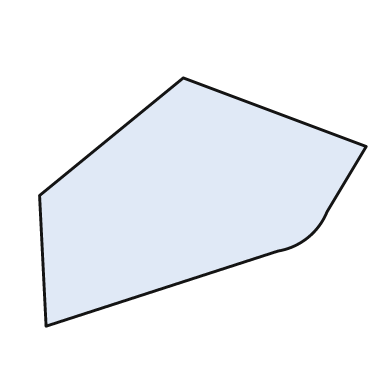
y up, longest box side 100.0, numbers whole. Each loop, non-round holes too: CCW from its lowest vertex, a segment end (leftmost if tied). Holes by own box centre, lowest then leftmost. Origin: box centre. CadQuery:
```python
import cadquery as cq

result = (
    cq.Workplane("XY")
    .moveTo(-48.0, -38.0)
    .lineTo(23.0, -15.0)
    .threePointArc((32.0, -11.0), (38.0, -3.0))
    .lineTo(50.0, 17.0)
    .lineTo(-6.0, 38.0)
    .lineTo(-50.0, 2.0)
    .close()
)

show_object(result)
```